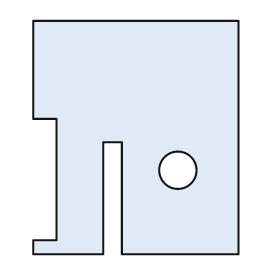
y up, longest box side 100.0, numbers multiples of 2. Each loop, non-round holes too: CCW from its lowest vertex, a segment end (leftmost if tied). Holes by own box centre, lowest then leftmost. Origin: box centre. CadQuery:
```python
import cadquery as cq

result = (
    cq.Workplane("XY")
    .moveTo(-44.0, -50.0)
    .lineTo(-14.0, -50.0)
    .lineTo(-14.0, -2.0)
    .lineTo(-6.0, -2.0)
    .lineTo(-6.0, -50.0)
    .lineTo(44.0, -50.0)
    .lineTo(44.0, 50.0)
    .lineTo(-44.0, 50.0)
    .lineTo(-44.0, 8.0)
    .lineTo(-34.0, 8.0)
    .lineTo(-34.0, -44.0)
    .lineTo(-44.0, -44.0)
    .close()
    .moveTo(18.0, -14.0)
    .circle(8.0)
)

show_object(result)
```